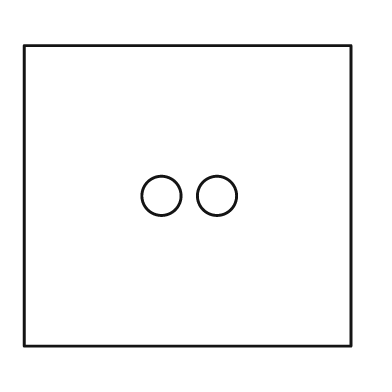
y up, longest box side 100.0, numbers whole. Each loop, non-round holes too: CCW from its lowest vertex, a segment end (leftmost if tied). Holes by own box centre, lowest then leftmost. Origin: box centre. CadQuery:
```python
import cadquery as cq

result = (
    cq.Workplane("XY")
    .moveTo(-50.0, -46.0)
    .lineTo(50.0, -46.0)
    .lineTo(50.0, 46.0)
    .lineTo(-50.0, 46.0)
    .close()
    .moveTo(-8.0, 0.0)
    .circle(6.0)
    .moveTo(9.0, 0.0)
    .circle(6.0)
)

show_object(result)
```